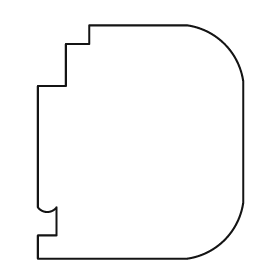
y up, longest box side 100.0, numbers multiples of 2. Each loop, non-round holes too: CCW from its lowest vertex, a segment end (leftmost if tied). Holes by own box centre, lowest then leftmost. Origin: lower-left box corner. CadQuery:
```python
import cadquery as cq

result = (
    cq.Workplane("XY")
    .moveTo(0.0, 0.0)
    .lineTo(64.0, 0.0)
    .threePointArc((80.0, 8.0), (88.0, 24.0))
    .lineTo(88.0, 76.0)
    .threePointArc((80.0, 92.0), (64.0, 100.0))
    .lineTo(22.0, 100.0)
    .lineTo(22.0, 92.0)
    .lineTo(12.0, 92.0)
    .lineTo(12.0, 74.0)
    .lineTo(0.0, 74.0)
    .lineTo(0.0, 22.0)
    .threePointArc((4.0, 20.0), (8.0, 22.0))
    .lineTo(8.0, 10.0)
    .lineTo(0.0, 10.0)
    .close()
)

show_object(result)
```